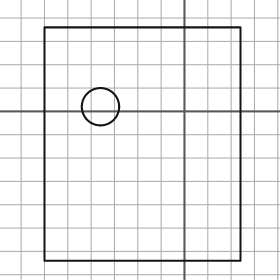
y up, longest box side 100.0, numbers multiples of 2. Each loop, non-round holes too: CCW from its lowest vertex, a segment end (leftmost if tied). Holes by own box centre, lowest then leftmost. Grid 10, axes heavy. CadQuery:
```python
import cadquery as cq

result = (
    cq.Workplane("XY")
    .moveTo(-60.0, -64.0)
    .lineTo(24.0, -64.0)
    .lineTo(24.0, 36.0)
    .lineTo(-60.0, 36.0)
    .close()
    .moveTo(-36.0, 2.0)
    .circle(8.0)
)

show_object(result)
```